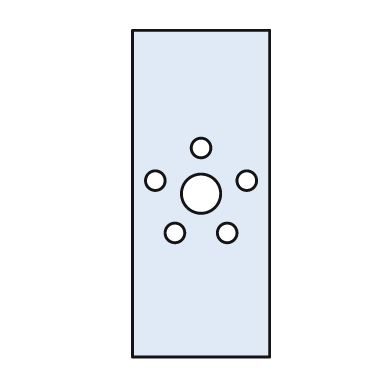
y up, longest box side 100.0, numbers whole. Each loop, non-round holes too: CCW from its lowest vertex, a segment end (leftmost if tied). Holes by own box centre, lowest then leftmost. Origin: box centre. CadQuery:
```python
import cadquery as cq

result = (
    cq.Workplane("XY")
    .moveTo(-21.0, -50.0)
    .lineTo(21.0, -50.0)
    .lineTo(21.0, 50.0)
    .lineTo(-21.0, 50.0)
    .close()
    .moveTo(-8.0, -12.0)
    .circle(3.0)
    .moveTo(8.0, -12.0)
    .circle(3.0)
    .moveTo(0.0, 0.0)
    .circle(6.0)
    .moveTo(-14.0, 4.0)
    .circle(3.0)
    .moveTo(14.0, 4.0)
    .circle(3.0)
    .moveTo(0.0, 14.0)
    .circle(3.0)
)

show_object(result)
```